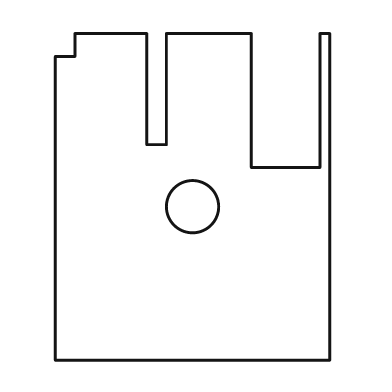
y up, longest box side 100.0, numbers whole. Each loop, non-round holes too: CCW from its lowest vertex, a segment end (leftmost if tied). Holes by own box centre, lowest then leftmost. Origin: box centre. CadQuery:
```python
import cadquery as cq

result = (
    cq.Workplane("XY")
    .moveTo(-42.0, -50.0)
    .lineTo(42.0, -50.0)
    .lineTo(42.0, 50.0)
    .lineTo(39.0, 50.0)
    .lineTo(39.0, 9.0)
    .lineTo(18.0, 9.0)
    .lineTo(18.0, 50.0)
    .lineTo(-8.0, 50.0)
    .lineTo(-8.0, 16.0)
    .lineTo(-14.0, 16.0)
    .lineTo(-14.0, 50.0)
    .lineTo(-36.0, 50.0)
    .lineTo(-36.0, 43.0)
    .lineTo(-42.0, 43.0)
    .close()
    .moveTo(0.0, -3.0)
    .circle(8.0)
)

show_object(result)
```